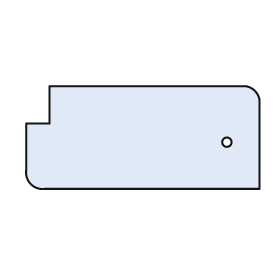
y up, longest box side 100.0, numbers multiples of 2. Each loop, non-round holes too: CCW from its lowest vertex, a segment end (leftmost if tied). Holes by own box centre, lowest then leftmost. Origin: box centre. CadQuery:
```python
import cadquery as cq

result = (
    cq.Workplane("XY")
    .moveTo(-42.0, -22.0)
    .lineTo(50.0, -22.0)
    .lineTo(50.0, 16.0)
    .threePointArc((48.0, 20.0), (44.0, 22.0))
    .lineTo(-40.0, 22.0)
    .lineTo(-40.0, 6.0)
    .lineTo(-50.0, 6.0)
    .lineTo(-50.0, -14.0)
    .threePointArc((-48.0, -20.0), (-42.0, -22.0))
    .close()
    .moveTo(36.0, -2.0)
    .circle(2.0)
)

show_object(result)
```